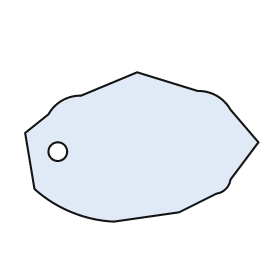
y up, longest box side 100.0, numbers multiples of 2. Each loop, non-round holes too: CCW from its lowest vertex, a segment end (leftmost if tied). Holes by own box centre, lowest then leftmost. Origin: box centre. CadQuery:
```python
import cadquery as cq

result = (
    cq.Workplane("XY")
    .moveTo(-12.0, -32.0)
    .lineTo(16.0, -28.0)
    .lineTo(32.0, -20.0)
    .threePointArc((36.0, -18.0), (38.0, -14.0))
    .lineTo(50.0, 2.0)
    .lineTo(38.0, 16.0)
    .threePointArc((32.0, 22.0), (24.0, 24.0))
    .lineTo(-2.0, 32.0)
    .lineTo(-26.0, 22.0)
    .threePointArc((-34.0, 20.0), (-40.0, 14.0))
    .lineTo(-50.0, 6.0)
    .lineTo(-46.0, -18.0)
    .threePointArc((-30.0, -28.0), (-12.0, -32.0))
    .close()
    .moveTo(-36.0, -2.0)
    .circle(4.0)
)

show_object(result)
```